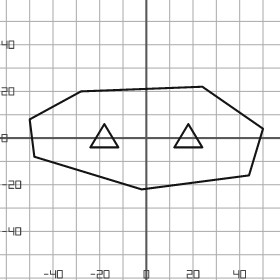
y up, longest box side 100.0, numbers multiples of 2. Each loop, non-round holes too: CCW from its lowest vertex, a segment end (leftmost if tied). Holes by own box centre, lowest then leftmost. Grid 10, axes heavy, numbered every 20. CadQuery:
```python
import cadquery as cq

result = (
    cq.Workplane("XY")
    .moveTo(-2.0, -22.0)
    .lineTo(44.0, -16.0)
    .lineTo(50.0, 4.0)
    .lineTo(24.0, 22.0)
    .lineTo(-28.0, 20.0)
    .lineTo(-50.0, 8.0)
    .lineTo(-48.0, -8.0)
    .close()
    .moveTo(-24.0, -4.0)
    .lineTo(-12.0, -4.0)
    .lineTo(-18.0, 6.0)
    .close()
    .moveTo(12.0, -4.0)
    .lineTo(24.0, -4.0)
    .lineTo(18.0, 6.0)
    .close()
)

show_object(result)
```